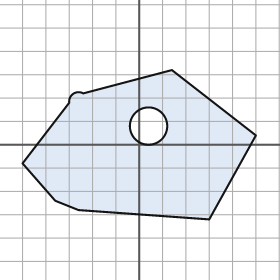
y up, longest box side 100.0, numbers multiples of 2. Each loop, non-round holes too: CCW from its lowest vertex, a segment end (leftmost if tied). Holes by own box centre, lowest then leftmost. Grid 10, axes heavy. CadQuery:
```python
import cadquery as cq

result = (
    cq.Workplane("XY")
    .moveTo(30.0, -32.0)
    .lineTo(50.0, 4.0)
    .lineTo(14.0, 32.0)
    .lineTo(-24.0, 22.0)
    .threePointArc((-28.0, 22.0), (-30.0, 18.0))
    .lineTo(-50.0, -8.0)
    .lineTo(-36.0, -24.0)
    .lineTo(-26.0, -28.0)
    .close()
    .moveTo(4.0, 8.0)
    .circle(8.0)
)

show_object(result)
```